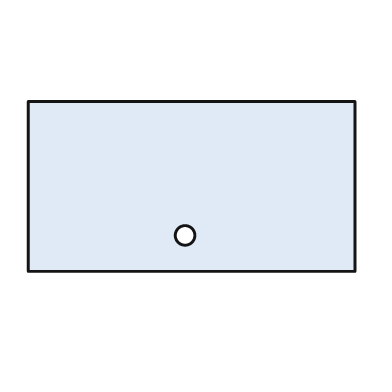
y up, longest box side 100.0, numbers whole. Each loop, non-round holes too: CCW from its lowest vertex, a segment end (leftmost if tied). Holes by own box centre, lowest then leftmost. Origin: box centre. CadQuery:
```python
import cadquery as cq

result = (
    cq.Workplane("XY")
    .moveTo(-50.0, -26.0)
    .lineTo(50.0, -26.0)
    .lineTo(50.0, 26.0)
    .lineTo(-50.0, 26.0)
    .close()
    .moveTo(-2.0, -15.0)
    .circle(3.0)
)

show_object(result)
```